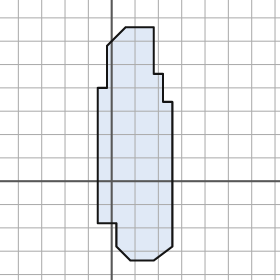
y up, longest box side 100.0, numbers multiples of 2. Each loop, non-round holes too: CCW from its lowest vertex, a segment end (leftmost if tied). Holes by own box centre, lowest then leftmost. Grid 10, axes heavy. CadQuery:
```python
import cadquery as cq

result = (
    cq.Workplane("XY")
    .moveTo(8.0, -34.0)
    .lineTo(18.0, -34.0)
    .lineTo(26.0, -28.0)
    .lineTo(26.0, 34.0)
    .lineTo(22.0, 34.0)
    .lineTo(22.0, 46.0)
    .lineTo(18.0, 46.0)
    .lineTo(18.0, 66.0)
    .lineTo(6.0, 66.0)
    .lineTo(-2.0, 58.0)
    .lineTo(-2.0, 40.0)
    .lineTo(-6.0, 40.0)
    .lineTo(-6.0, -18.0)
    .lineTo(2.0, -18.0)
    .lineTo(2.0, -28.0)
    .close()
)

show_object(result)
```